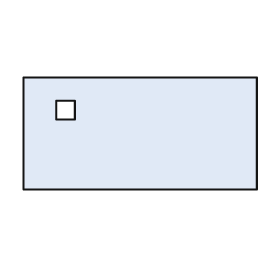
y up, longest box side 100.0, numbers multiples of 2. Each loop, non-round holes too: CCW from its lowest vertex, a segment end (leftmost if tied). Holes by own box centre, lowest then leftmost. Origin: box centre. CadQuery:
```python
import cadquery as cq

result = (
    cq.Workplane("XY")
    .moveTo(-50.0, -24.0)
    .lineTo(50.0, -24.0)
    .lineTo(50.0, 24.0)
    .lineTo(-50.0, 24.0)
    .close()
    .moveTo(-36.0, 6.0)
    .lineTo(-28.0, 6.0)
    .lineTo(-28.0, 14.0)
    .lineTo(-36.0, 14.0)
    .close()
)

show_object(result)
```